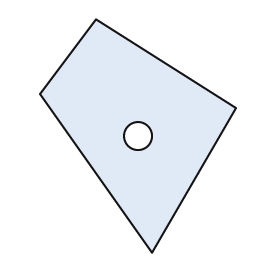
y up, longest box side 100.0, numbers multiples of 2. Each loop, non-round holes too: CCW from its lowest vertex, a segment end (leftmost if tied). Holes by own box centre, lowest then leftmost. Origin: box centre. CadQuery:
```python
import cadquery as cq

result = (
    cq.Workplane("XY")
    .moveTo(6.0, -50.0)
    .lineTo(42.0, 12.0)
    .lineTo(-18.0, 50.0)
    .lineTo(-42.0, 18.0)
    .close()
    .moveTo(0.0, 0.0)
    .circle(6.0)
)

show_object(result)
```